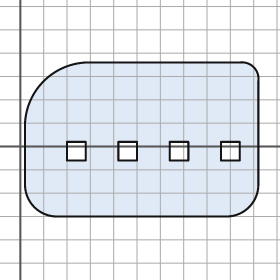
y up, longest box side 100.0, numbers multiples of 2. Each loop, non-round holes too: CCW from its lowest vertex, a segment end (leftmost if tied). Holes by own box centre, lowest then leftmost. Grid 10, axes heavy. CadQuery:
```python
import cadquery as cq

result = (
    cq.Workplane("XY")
    .moveTo(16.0, -30.0)
    .lineTo(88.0, -30.0)
    .threePointArc((98.0, -26.0), (102.0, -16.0))
    .lineTo(102.0, 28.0)
    .threePointArc((100.0, 34.0), (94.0, 36.0))
    .lineTo(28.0, 36.0)
    .threePointArc((10.0, 28.0), (2.0, 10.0))
    .lineTo(2.0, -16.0)
    .threePointArc((6.0, -26.0), (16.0, -30.0))
    .close()
    .moveTo(20.0, -6.0)
    .lineTo(28.0, -6.0)
    .lineTo(28.0, 2.0)
    .lineTo(20.0, 2.0)
    .close()
    .moveTo(42.0, -6.0)
    .lineTo(50.0, -6.0)
    .lineTo(50.0, 2.0)
    .lineTo(42.0, 2.0)
    .close()
    .moveTo(64.0, -6.0)
    .lineTo(72.0, -6.0)
    .lineTo(72.0, 2.0)
    .lineTo(64.0, 2.0)
    .close()
    .moveTo(86.0, -6.0)
    .lineTo(94.0, -6.0)
    .lineTo(94.0, 2.0)
    .lineTo(86.0, 2.0)
    .close()
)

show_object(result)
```